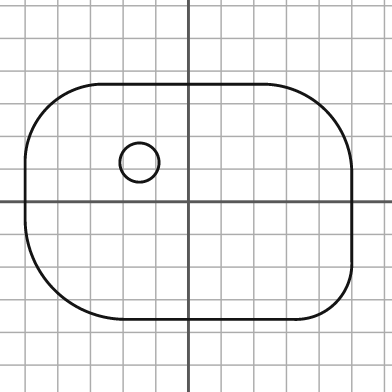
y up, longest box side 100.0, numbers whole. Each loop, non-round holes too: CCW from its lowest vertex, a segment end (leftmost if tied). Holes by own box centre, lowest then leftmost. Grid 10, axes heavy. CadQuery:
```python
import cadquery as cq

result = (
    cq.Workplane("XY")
    .moveTo(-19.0, -36.0)
    .lineTo(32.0, -36.0)
    .threePointArc((45.0, -31.0), (50.0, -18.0))
    .lineTo(50.0, 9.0)
    .threePointArc((42.0, 28.0), (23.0, 36.0))
    .lineTo(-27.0, 36.0)
    .threePointArc((-43.0, 29.0), (-50.0, 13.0))
    .lineTo(-50.0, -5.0)
    .threePointArc((-41.0, -27.0), (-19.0, -36.0))
    .close()
    .moveTo(-15.0, 12.0)
    .circle(6.0)
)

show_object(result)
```